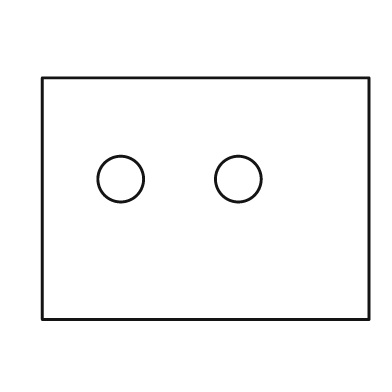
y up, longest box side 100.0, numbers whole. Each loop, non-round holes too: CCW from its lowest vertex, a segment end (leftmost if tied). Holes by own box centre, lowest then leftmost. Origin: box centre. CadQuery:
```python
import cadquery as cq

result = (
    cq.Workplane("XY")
    .moveTo(-50.0, -37.0)
    .lineTo(50.0, -37.0)
    .lineTo(50.0, 37.0)
    .lineTo(-50.0, 37.0)
    .close()
    .moveTo(-26.0, 6.0)
    .circle(7.0)
    .moveTo(10.0, 6.0)
    .circle(7.0)
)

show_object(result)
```